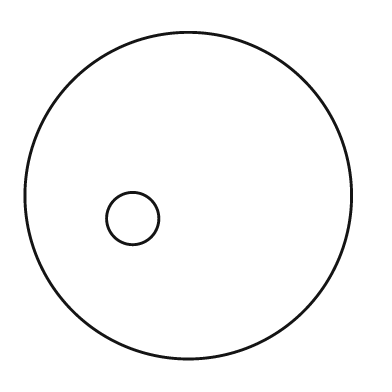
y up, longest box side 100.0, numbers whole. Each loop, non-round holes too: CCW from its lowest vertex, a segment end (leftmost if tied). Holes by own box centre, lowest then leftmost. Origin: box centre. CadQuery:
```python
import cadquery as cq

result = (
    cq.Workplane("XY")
    .moveTo(0.0, 0.0)
    .circle(50.0)
    .moveTo(-17.0, -7.0)
    .circle(8.0)
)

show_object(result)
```